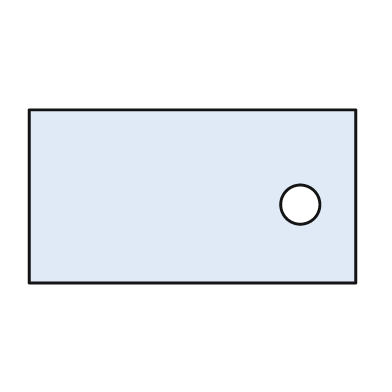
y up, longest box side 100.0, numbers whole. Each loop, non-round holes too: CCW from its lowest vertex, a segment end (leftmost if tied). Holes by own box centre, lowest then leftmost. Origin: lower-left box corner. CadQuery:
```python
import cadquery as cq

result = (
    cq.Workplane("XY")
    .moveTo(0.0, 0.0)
    .lineTo(100.0, 0.0)
    .lineTo(100.0, 53.0)
    .lineTo(0.0, 53.0)
    .close()
    .moveTo(83.0, 24.0)
    .circle(6.0)
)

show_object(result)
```